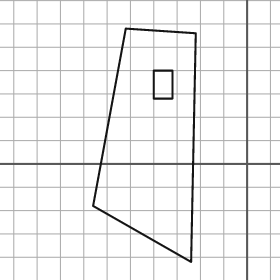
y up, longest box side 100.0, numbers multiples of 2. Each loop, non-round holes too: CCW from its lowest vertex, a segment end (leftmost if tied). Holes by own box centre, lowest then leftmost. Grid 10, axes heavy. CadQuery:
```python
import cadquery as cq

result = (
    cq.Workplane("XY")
    .moveTo(-24.0, -42.0)
    .lineTo(-22.0, 56.0)
    .lineTo(-52.0, 58.0)
    .lineTo(-66.0, -18.0)
    .close()
    .moveTo(-40.0, 28.0)
    .lineTo(-32.0, 28.0)
    .lineTo(-32.0, 40.0)
    .lineTo(-40.0, 40.0)
    .close()
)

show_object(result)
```